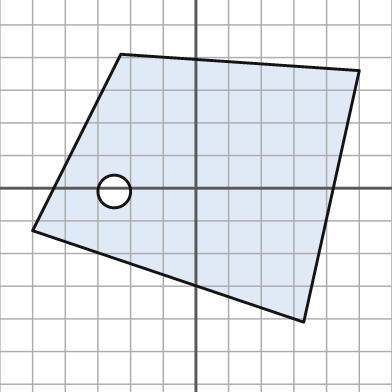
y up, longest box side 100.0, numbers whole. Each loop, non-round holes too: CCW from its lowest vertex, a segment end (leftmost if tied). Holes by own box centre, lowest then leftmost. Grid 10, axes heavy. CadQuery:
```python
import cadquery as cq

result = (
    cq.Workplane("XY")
    .moveTo(33.0, -41.0)
    .lineTo(50.0, 36.0)
    .lineTo(-23.0, 41.0)
    .lineTo(-50.0, -13.0)
    .close()
    .moveTo(-25.0, -1.0)
    .circle(5.0)
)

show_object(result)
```